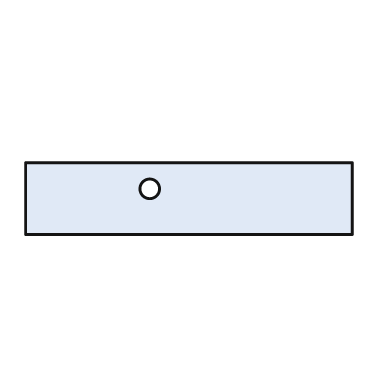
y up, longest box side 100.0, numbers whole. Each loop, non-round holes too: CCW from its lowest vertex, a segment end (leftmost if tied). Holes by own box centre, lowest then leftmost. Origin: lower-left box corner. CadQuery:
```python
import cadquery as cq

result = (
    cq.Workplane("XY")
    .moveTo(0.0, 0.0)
    .lineTo(100.0, 0.0)
    .lineTo(100.0, 22.0)
    .lineTo(0.0, 22.0)
    .close()
    .moveTo(38.0, 14.0)
    .circle(3.0)
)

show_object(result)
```